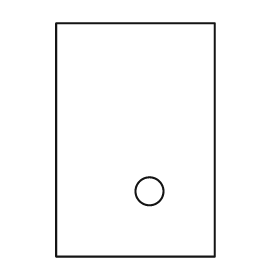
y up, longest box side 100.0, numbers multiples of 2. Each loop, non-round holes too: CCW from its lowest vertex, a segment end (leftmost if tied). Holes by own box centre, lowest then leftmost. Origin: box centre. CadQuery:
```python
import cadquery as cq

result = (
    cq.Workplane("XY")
    .moveTo(-34.0, -50.0)
    .lineTo(34.0, -50.0)
    .lineTo(34.0, 50.0)
    .lineTo(-34.0, 50.0)
    .close()
    .moveTo(6.0, -22.0)
    .circle(6.0)
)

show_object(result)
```